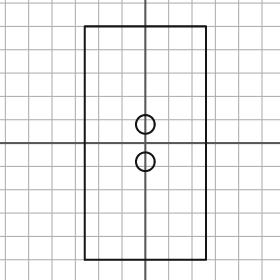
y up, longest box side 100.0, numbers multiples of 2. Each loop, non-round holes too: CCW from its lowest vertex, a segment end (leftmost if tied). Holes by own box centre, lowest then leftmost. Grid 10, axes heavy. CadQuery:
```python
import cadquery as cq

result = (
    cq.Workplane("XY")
    .moveTo(-26.0, -50.0)
    .lineTo(26.0, -50.0)
    .lineTo(26.0, 50.0)
    .lineTo(-26.0, 50.0)
    .close()
    .moveTo(0.0, -8.0)
    .circle(4.0)
    .moveTo(0.0, 8.0)
    .circle(4.0)
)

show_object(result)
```